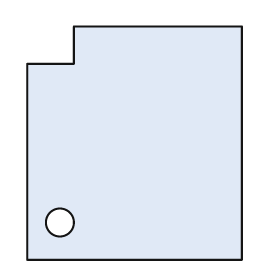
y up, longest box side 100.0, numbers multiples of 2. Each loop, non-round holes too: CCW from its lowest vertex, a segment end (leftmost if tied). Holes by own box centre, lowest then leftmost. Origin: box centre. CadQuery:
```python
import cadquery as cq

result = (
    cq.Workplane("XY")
    .moveTo(-46.0, -50.0)
    .lineTo(46.0, -50.0)
    .lineTo(46.0, 50.0)
    .lineTo(-26.0, 50.0)
    .lineTo(-26.0, 34.0)
    .lineTo(-46.0, 34.0)
    .close()
    .moveTo(-32.0, -34.0)
    .circle(6.0)
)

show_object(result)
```